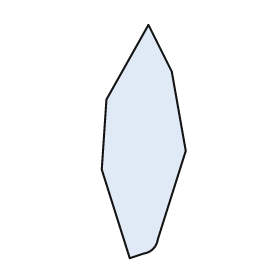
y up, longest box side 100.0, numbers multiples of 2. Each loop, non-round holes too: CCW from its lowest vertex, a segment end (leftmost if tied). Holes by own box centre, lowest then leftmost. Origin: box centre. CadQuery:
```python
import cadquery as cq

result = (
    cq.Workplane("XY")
    .moveTo(-6.0, -50.0)
    .lineTo(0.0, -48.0)
    .threePointArc((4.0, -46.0), (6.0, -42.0))
    .lineTo(18.0, -4.0)
    .lineTo(12.0, 30.0)
    .lineTo(2.0, 50.0)
    .lineTo(-16.0, 18.0)
    .lineTo(-18.0, -12.0)
    .close()
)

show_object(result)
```